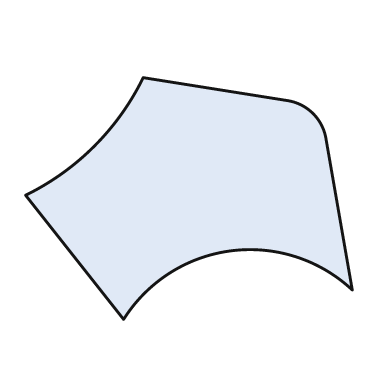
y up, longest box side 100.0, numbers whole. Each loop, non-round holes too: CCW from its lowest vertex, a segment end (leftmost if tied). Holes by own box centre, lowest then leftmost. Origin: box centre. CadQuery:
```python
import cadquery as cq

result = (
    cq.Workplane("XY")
    .moveTo(-20.0, -37.0)
    .threePointArc((13.0, -16.0), (50.0, -28.0))
    .lineTo(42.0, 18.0)
    .threePointArc((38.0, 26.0), (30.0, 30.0))
    .lineTo(-14.0, 37.0)
    .threePointArc((-29.0, 16.0), (-50.0, 1.0))
    .close()
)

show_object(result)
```